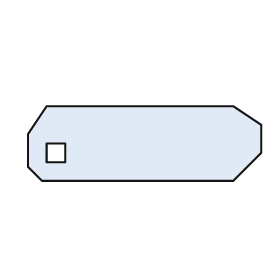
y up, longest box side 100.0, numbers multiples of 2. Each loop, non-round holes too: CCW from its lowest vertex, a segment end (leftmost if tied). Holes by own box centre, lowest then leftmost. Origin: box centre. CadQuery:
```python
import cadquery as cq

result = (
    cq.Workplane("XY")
    .moveTo(-44.0, -16.0)
    .lineTo(38.0, -16.0)
    .lineTo(50.0, -4.0)
    .lineTo(50.0, 8.0)
    .lineTo(38.0, 16.0)
    .lineTo(-42.0, 16.0)
    .lineTo(-50.0, 4.0)
    .lineTo(-50.0, -10.0)
    .close()
    .moveTo(-42.0, -8.0)
    .lineTo(-34.0, -8.0)
    .lineTo(-34.0, 0.0)
    .lineTo(-42.0, 0.0)
    .close()
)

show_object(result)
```